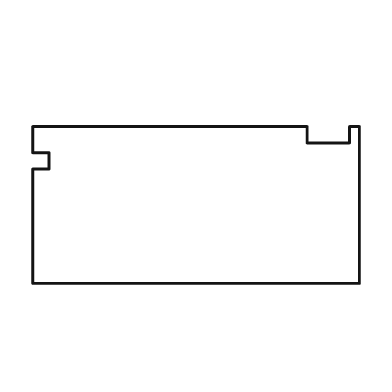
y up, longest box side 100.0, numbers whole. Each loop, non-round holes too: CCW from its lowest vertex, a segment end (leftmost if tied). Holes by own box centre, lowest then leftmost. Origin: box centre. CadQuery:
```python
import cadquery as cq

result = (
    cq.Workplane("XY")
    .moveTo(-50.0, -24.0)
    .lineTo(50.0, -24.0)
    .lineTo(50.0, 24.0)
    .lineTo(47.0, 24.0)
    .lineTo(47.0, 19.0)
    .lineTo(34.0, 19.0)
    .lineTo(34.0, 24.0)
    .lineTo(-50.0, 24.0)
    .lineTo(-50.0, 16.0)
    .lineTo(-45.0, 16.0)
    .lineTo(-45.0, 11.0)
    .lineTo(-50.0, 11.0)
    .close()
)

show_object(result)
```